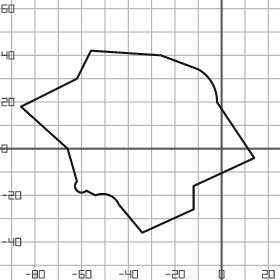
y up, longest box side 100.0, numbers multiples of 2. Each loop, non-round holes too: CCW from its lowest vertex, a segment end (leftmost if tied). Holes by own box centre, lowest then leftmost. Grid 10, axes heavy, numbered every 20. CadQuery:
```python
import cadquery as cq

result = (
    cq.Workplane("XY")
    .moveTo(-34.0, -36.0)
    .lineTo(-12.0, -26.0)
    .lineTo(-12.0, -16.0)
    .lineTo(14.0, -4.0)
    .lineTo(-2.0, 20.0)
    .threePointArc((-4.0, 28.0), (-10.0, 34.0))
    .lineTo(-26.0, 40.0)
    .lineTo(-56.0, 42.0)
    .lineTo(-62.0, 30.0)
    .lineTo(-86.0, 18.0)
    .lineTo(-66.0, 0.0)
    .lineTo(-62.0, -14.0)
    .threePointArc((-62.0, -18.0), (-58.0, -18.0))
    .lineTo(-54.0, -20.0)
    .threePointArc((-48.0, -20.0), (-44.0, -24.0))
    .close()
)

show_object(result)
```